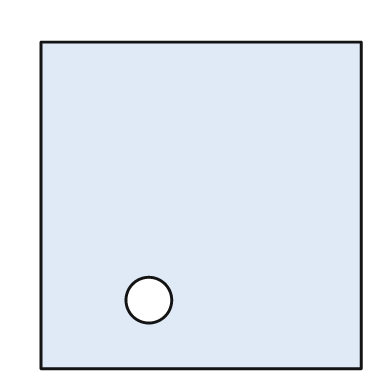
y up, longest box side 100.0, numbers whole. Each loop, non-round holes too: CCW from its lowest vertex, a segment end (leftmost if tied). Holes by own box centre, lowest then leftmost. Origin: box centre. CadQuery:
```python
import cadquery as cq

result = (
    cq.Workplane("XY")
    .moveTo(-49.0, -50.0)
    .lineTo(49.0, -50.0)
    .lineTo(49.0, 50.0)
    .lineTo(-49.0, 50.0)
    .close()
    .moveTo(-16.0, -29.0)
    .circle(7.0)
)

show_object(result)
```